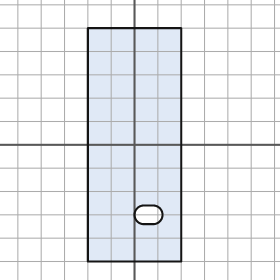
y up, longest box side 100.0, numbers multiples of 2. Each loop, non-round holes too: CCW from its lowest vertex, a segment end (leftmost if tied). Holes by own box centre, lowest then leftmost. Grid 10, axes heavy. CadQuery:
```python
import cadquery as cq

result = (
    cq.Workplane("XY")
    .moveTo(-20.0, -50.0)
    .lineTo(20.0, -50.0)
    .lineTo(20.0, 50.0)
    .lineTo(-20.0, 50.0)
    .close()
    .moveTo(4.0, -34.0)
    .lineTo(8.0, -34.0)
    .threePointArc((12.0, -30.0), (8.0, -26.0))
    .lineTo(4.0, -26.0)
    .threePointArc((0.0, -30.0), (4.0, -34.0))
    .close()
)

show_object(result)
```